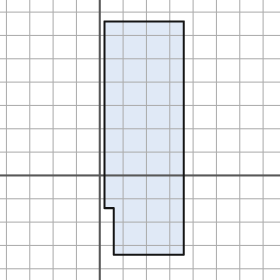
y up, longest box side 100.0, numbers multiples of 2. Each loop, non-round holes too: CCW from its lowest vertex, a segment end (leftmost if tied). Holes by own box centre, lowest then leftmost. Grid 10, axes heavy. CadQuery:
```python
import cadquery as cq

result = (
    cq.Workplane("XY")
    .moveTo(6.0, -34.0)
    .lineTo(36.0, -34.0)
    .lineTo(36.0, 66.0)
    .lineTo(2.0, 66.0)
    .lineTo(2.0, -14.0)
    .lineTo(6.0, -14.0)
    .close()
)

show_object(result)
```